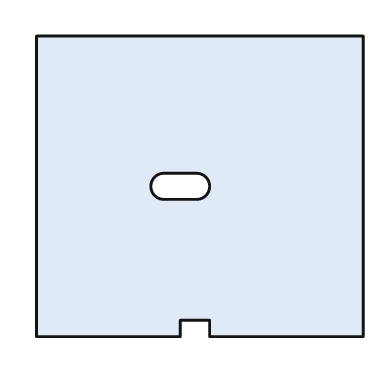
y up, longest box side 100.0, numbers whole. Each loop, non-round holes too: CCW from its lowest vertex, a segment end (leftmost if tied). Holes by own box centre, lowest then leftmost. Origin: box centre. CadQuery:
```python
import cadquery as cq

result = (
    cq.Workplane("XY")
    .moveTo(-50.0, -46.0)
    .lineTo(-6.0, -46.0)
    .lineTo(-6.0, -41.0)
    .lineTo(3.0, -41.0)
    .lineTo(3.0, -46.0)
    .lineTo(50.0, -46.0)
    .lineTo(50.0, 46.0)
    .lineTo(-50.0, 46.0)
    .close()
    .moveTo(-11.0, -4.0)
    .lineTo(-1.0, -4.0)
    .threePointArc((3.0, 0.0), (-1.0, 4.0))
    .lineTo(-11.0, 4.0)
    .threePointArc((-15.0, 0.0), (-11.0, -4.0))
    .close()
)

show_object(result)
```